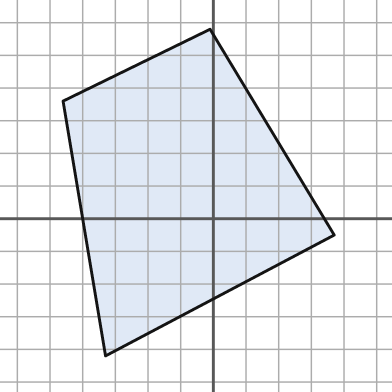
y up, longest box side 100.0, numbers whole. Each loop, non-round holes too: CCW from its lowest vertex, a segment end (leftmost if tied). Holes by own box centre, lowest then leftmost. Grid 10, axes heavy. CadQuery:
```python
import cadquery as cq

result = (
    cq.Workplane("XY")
    .moveTo(-33.0, -42.0)
    .lineTo(37.0, -5.0)
    .lineTo(-1.0, 58.0)
    .lineTo(-46.0, 36.0)
    .close()
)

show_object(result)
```